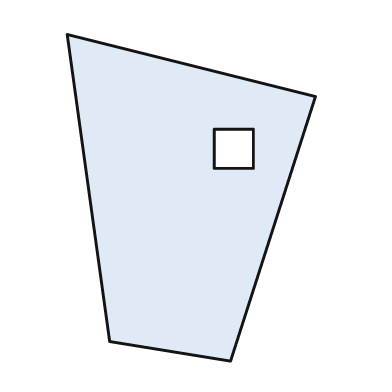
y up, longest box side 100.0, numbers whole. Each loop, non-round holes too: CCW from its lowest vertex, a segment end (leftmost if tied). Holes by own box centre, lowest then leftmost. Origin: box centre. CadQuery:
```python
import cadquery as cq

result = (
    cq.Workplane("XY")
    .moveTo(12.0, -50.0)
    .lineTo(38.0, 31.0)
    .lineTo(-38.0, 50.0)
    .lineTo(-25.0, -44.0)
    .close()
    .moveTo(7.0, 9.0)
    .lineTo(19.0, 9.0)
    .lineTo(19.0, 21.0)
    .lineTo(7.0, 21.0)
    .close()
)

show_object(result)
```